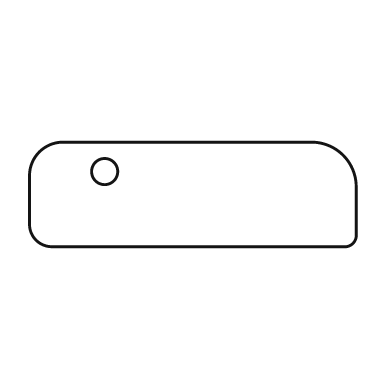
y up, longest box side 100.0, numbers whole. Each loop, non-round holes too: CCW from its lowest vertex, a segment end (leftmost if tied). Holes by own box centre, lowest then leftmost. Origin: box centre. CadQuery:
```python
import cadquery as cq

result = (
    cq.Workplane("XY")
    .moveTo(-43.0, -16.0)
    .lineTo(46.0, -16.0)
    .threePointArc((49.0, -15.0), (50.0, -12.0))
    .lineTo(50.0, 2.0)
    .threePointArc((46.0, 12.0), (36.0, 16.0))
    .lineTo(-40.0, 16.0)
    .threePointArc((-47.0, 13.0), (-50.0, 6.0))
    .lineTo(-50.0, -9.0)
    .threePointArc((-48.0, -14.0), (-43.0, -16.0))
    .close()
    .moveTo(-27.0, 7.0)
    .circle(4.0)
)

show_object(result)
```